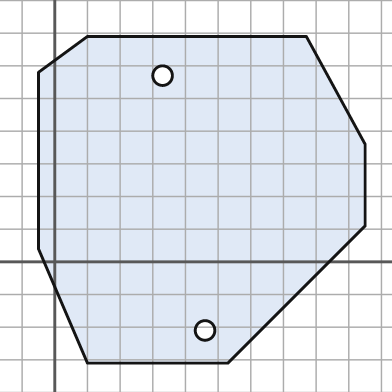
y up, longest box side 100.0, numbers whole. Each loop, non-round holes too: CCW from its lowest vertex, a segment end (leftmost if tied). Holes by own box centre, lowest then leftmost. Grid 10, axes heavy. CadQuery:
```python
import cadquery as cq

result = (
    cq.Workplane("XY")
    .moveTo(10.0, -31.0)
    .lineTo(53.0, -31.0)
    .lineTo(95.0, 11.0)
    .lineTo(95.0, 36.0)
    .lineTo(77.0, 69.0)
    .lineTo(10.0, 69.0)
    .lineTo(-5.0, 58.0)
    .lineTo(-5.0, 4.0)
    .close()
    .moveTo(46.0, -21.0)
    .circle(3.0)
    .moveTo(33.0, 57.0)
    .circle(3.0)
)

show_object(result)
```